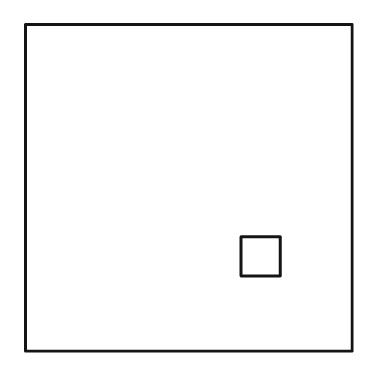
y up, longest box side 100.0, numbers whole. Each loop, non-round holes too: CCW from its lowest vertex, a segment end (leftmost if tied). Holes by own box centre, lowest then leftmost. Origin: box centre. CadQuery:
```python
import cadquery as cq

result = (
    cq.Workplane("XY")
    .moveTo(-50.0, -50.0)
    .lineTo(50.0, -50.0)
    .lineTo(50.0, 50.0)
    .lineTo(-50.0, 50.0)
    .close()
    .moveTo(16.0, -27.0)
    .lineTo(28.0, -27.0)
    .lineTo(28.0, -15.0)
    .lineTo(16.0, -15.0)
    .close()
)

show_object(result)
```